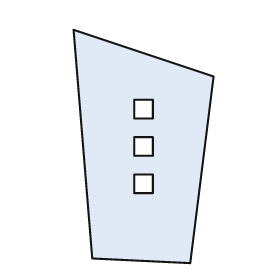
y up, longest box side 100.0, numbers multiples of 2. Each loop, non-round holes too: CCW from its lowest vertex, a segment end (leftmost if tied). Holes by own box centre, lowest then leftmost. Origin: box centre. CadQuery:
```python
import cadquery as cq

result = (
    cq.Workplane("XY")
    .moveTo(20.0, -50.0)
    .lineTo(30.0, 30.0)
    .lineTo(-30.0, 50.0)
    .lineTo(-22.0, -48.0)
    .close()
    .moveTo(-4.0, -20.0)
    .lineTo(4.0, -20.0)
    .lineTo(4.0, -12.0)
    .lineTo(-4.0, -12.0)
    .close()
    .moveTo(-4.0, -4.0)
    .lineTo(4.0, -4.0)
    .lineTo(4.0, 4.0)
    .lineTo(-4.0, 4.0)
    .close()
    .moveTo(-4.0, 12.0)
    .lineTo(4.0, 12.0)
    .lineTo(4.0, 20.0)
    .lineTo(-4.0, 20.0)
    .close()
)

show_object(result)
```